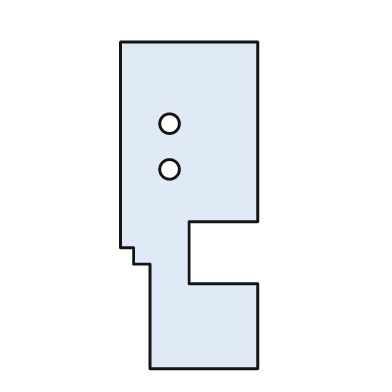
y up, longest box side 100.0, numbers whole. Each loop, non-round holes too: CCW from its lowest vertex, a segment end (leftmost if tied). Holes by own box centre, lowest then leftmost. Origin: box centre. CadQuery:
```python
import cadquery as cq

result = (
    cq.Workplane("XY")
    .moveTo(-12.0, -50.0)
    .lineTo(21.0, -50.0)
    .lineTo(21.0, -24.0)
    .lineTo(0.0, -24.0)
    .lineTo(0.0, -5.0)
    .lineTo(21.0, -5.0)
    .lineTo(21.0, 50.0)
    .lineTo(-21.0, 50.0)
    .lineTo(-21.0, -13.0)
    .lineTo(-17.0, -13.0)
    .lineTo(-17.0, -18.0)
    .lineTo(-12.0, -18.0)
    .close()
    .moveTo(-6.0, 11.0)
    .circle(3.0)
    .moveTo(-6.0, 25.0)
    .circle(3.0)
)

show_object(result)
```